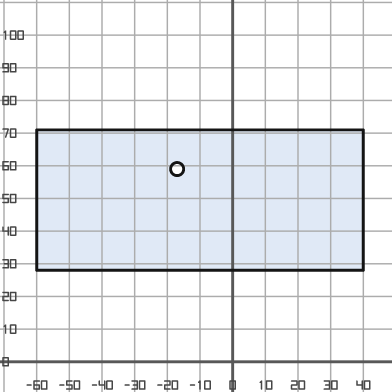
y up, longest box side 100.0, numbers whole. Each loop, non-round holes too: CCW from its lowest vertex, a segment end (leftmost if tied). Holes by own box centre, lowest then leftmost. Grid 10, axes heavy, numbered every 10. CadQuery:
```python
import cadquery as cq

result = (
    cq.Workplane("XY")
    .moveTo(-60.0, 28.0)
    .lineTo(40.0, 28.0)
    .lineTo(40.0, 71.0)
    .lineTo(-60.0, 71.0)
    .close()
    .moveTo(-17.0, 59.0)
    .circle(2.0)
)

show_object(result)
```